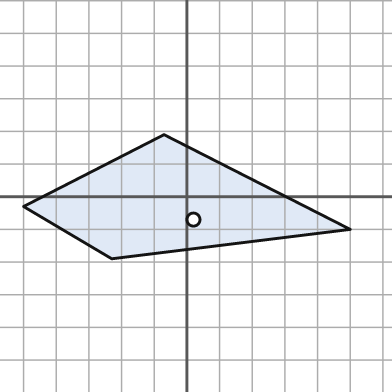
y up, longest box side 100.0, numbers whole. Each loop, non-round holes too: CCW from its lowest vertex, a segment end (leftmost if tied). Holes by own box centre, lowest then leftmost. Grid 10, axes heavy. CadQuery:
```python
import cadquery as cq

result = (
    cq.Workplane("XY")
    .moveTo(-23.0, -19.0)
    .lineTo(50.0, -10.0)
    .lineTo(-7.0, 19.0)
    .lineTo(-50.0, -3.0)
    .close()
    .moveTo(2.0, -7.0)
    .circle(2.0)
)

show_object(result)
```